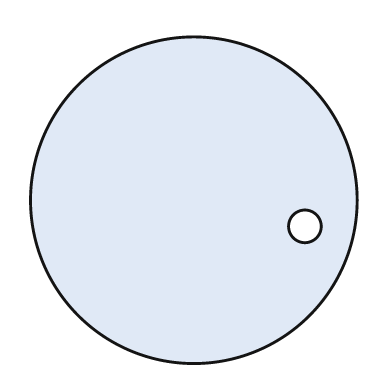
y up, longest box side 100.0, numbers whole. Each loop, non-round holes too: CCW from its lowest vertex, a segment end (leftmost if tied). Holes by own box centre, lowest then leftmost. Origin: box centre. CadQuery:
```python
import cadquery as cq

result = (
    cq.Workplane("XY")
    .moveTo(0.0, 0.0)
    .circle(50.0)
    .moveTo(34.0, -8.0)
    .circle(5.0)
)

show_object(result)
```